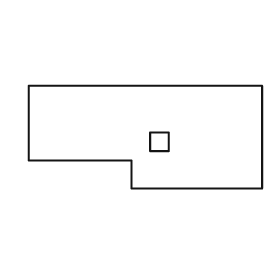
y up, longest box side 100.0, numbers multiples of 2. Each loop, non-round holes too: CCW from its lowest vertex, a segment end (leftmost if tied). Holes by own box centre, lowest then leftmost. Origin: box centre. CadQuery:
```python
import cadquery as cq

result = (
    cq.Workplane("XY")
    .moveTo(-6.0, -22.0)
    .lineTo(50.0, -22.0)
    .lineTo(50.0, 22.0)
    .lineTo(-50.0, 22.0)
    .lineTo(-50.0, -10.0)
    .lineTo(-6.0, -10.0)
    .close()
    .moveTo(2.0, -6.0)
    .lineTo(10.0, -6.0)
    .lineTo(10.0, 2.0)
    .lineTo(2.0, 2.0)
    .close()
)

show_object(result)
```